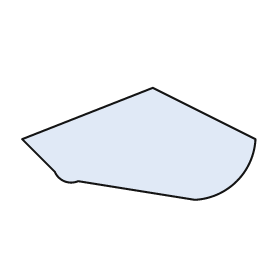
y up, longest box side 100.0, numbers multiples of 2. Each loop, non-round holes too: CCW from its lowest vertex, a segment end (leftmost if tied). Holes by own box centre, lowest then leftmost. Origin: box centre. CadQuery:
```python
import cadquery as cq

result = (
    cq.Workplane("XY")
    .moveTo(24.0, -24.0)
    .threePointArc((42.0, -16.0), (50.0, 2.0))
    .lineTo(6.0, 24.0)
    .lineTo(-50.0, 2.0)
    .lineTo(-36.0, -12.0)
    .threePointArc((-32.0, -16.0), (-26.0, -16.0))
    .close()
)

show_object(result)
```